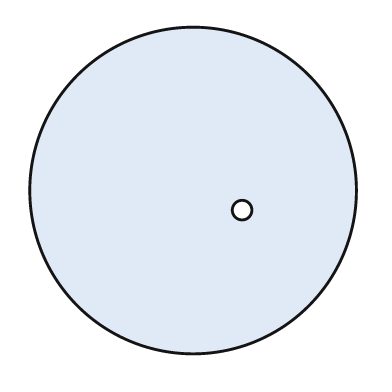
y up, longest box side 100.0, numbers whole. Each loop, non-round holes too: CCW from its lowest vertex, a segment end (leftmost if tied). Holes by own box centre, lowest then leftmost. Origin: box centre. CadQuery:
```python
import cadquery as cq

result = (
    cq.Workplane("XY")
    .moveTo(0.0, 0.0)
    .circle(50.0)
    .moveTo(15.0, -6.0)
    .circle(3.0)
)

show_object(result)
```